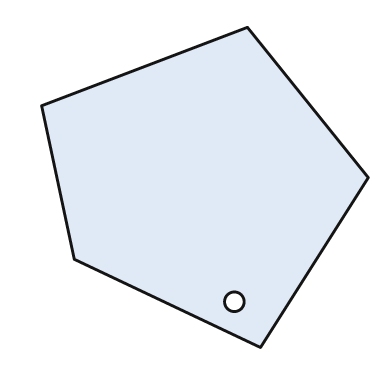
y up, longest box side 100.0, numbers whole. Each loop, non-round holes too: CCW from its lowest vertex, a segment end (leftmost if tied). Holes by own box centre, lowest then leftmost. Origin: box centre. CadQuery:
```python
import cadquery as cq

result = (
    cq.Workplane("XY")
    .moveTo(17.0, -49.0)
    .lineTo(50.0, 3.0)
    .lineTo(13.0, 49.0)
    .lineTo(-50.0, 25.0)
    .lineTo(-40.0, -22.0)
    .close()
    .moveTo(9.0, -35.0)
    .circle(3.0)
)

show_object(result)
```